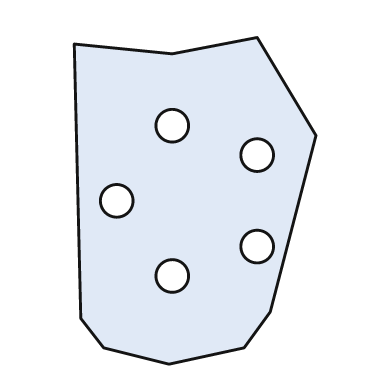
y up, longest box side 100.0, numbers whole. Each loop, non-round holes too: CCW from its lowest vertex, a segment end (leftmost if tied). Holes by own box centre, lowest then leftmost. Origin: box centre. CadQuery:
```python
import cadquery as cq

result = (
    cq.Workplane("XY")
    .moveTo(-8.0, -50.0)
    .lineTo(15.0, -45.0)
    .lineTo(23.0, -34.0)
    .lineTo(37.0, 20.0)
    .lineTo(19.0, 50.0)
    .lineTo(-7.0, 45.0)
    .lineTo(-37.0, 48.0)
    .lineTo(-35.0, -36.0)
    .lineTo(-28.0, -45.0)
    .close()
    .moveTo(-7.0, -23.0)
    .circle(5.0)
    .moveTo(19.0, -14.0)
    .circle(5.0)
    .moveTo(-24.0, 0.0)
    .circle(5.0)
    .moveTo(19.0, 14.0)
    .circle(5.0)
    .moveTo(-7.0, 23.0)
    .circle(5.0)
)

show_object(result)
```